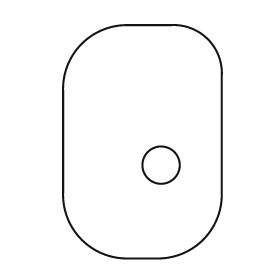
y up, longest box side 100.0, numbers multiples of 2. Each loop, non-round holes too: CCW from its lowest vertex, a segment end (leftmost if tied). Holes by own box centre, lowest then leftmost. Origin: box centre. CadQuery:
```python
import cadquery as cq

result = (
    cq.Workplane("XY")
    .moveTo(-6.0, -50.0)
    .lineTo(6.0, -50.0)
    .threePointArc((26.0, -42.0), (34.0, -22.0))
    .lineTo(34.0, 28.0)
    .threePointArc((28.0, 44.0), (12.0, 50.0))
    .lineTo(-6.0, 50.0)
    .threePointArc((-26.0, 42.0), (-34.0, 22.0))
    .lineTo(-34.0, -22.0)
    .threePointArc((-26.0, -42.0), (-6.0, -50.0))
    .close()
    .moveTo(8.0, -10.0)
    .circle(8.0)
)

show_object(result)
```